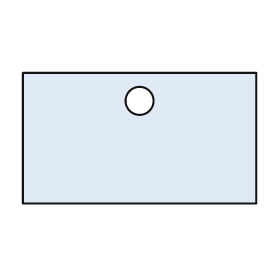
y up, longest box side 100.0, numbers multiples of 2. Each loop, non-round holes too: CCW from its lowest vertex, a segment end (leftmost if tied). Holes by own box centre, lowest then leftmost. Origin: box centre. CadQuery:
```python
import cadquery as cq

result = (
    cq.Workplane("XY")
    .moveTo(-50.0, -28.0)
    .lineTo(50.0, -28.0)
    .lineTo(50.0, 28.0)
    .lineTo(-50.0, 28.0)
    .close()
    .moveTo(0.0, 16.0)
    .circle(6.0)
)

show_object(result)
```